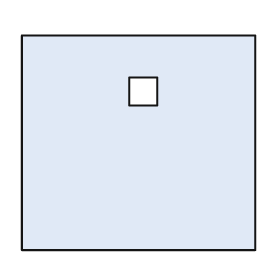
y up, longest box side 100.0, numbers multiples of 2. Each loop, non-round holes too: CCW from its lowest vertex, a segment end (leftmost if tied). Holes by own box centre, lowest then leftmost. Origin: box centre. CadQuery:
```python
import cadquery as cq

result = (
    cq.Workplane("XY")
    .moveTo(-50.0, -46.0)
    .lineTo(50.0, -46.0)
    .lineTo(50.0, 46.0)
    .lineTo(-50.0, 46.0)
    .close()
    .moveTo(-4.0, 16.0)
    .lineTo(8.0, 16.0)
    .lineTo(8.0, 28.0)
    .lineTo(-4.0, 28.0)
    .close()
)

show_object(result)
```